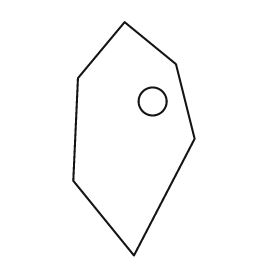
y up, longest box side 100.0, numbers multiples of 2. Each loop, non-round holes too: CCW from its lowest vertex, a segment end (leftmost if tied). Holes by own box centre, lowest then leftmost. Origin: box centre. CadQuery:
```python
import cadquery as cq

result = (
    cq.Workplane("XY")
    .moveTo(0.0, -50.0)
    .lineTo(26.0, 0.0)
    .lineTo(18.0, 32.0)
    .lineTo(-4.0, 50.0)
    .lineTo(-24.0, 26.0)
    .lineTo(-26.0, -18.0)
    .close()
    .moveTo(8.0, 16.0)
    .circle(6.0)
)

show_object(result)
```